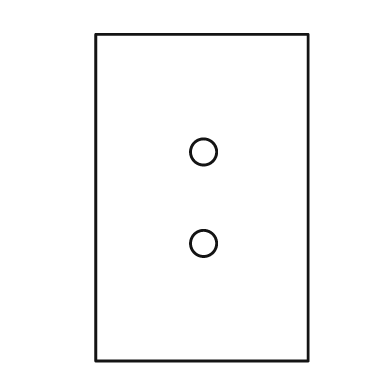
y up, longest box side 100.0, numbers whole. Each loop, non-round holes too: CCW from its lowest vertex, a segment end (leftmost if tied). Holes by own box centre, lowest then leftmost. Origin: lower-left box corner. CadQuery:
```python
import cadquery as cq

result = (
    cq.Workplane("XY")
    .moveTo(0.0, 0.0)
    .lineTo(65.0, 0.0)
    .lineTo(65.0, 100.0)
    .lineTo(0.0, 100.0)
    .close()
    .moveTo(33.0, 36.0)
    .circle(4.0)
    .moveTo(33.0, 64.0)
    .circle(4.0)
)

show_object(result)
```